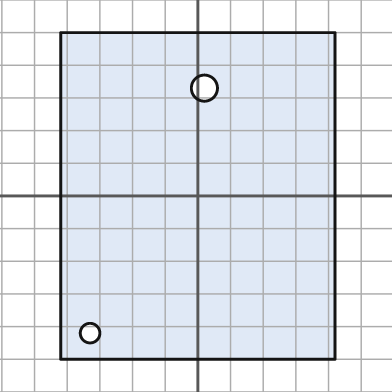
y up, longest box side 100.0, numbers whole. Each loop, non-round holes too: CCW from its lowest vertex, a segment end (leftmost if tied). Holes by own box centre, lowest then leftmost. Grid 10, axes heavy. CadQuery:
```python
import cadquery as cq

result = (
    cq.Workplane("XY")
    .moveTo(-42.0, -50.0)
    .lineTo(42.0, -50.0)
    .lineTo(42.0, 50.0)
    .lineTo(-42.0, 50.0)
    .close()
    .moveTo(-33.0, -42.0)
    .circle(3.0)
    .moveTo(2.0, 33.0)
    .circle(4.0)
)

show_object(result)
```